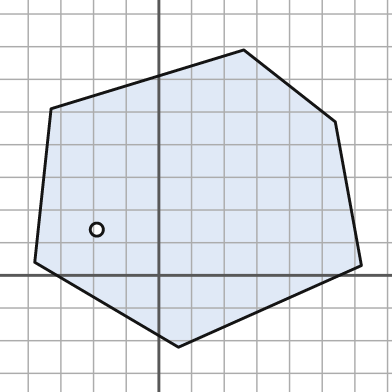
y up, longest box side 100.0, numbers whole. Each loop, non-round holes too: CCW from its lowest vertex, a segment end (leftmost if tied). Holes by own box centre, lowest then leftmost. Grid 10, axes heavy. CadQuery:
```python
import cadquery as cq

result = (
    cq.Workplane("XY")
    .moveTo(6.0, -22.0)
    .lineTo(62.0, 3.0)
    .lineTo(54.0, 47.0)
    .lineTo(26.0, 69.0)
    .lineTo(-33.0, 51.0)
    .lineTo(-38.0, 4.0)
    .close()
    .moveTo(-19.0, 14.0)
    .circle(2.0)
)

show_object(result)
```